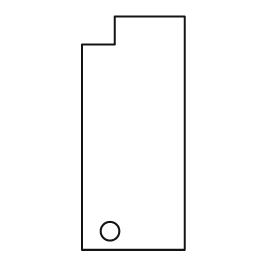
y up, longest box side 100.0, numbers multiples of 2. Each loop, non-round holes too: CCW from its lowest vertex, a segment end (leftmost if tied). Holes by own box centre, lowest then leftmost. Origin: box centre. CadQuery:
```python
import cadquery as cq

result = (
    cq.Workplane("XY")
    .moveTo(-22.0, -50.0)
    .lineTo(22.0, -50.0)
    .lineTo(22.0, 50.0)
    .lineTo(-8.0, 50.0)
    .lineTo(-8.0, 38.0)
    .lineTo(-22.0, 38.0)
    .close()
    .moveTo(-10.0, -42.0)
    .circle(4.0)
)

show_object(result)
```